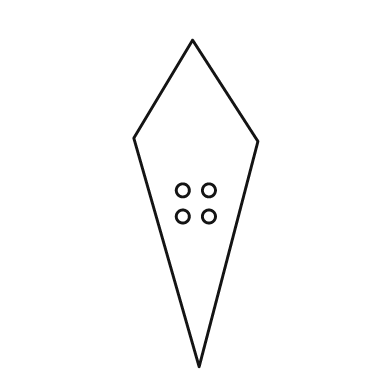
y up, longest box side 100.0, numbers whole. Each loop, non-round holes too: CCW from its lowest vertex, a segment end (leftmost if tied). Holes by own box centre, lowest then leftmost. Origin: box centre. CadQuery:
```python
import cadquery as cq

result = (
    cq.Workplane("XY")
    .moveTo(1.0, -50.0)
    .lineTo(19.0, 19.0)
    .lineTo(-1.0, 50.0)
    .lineTo(-19.0, 20.0)
    .close()
    .moveTo(-4.0, -4.0)
    .circle(2.0)
    .moveTo(4.0, -4.0)
    .circle(2.0)
    .moveTo(-4.0, 4.0)
    .circle(2.0)
    .moveTo(4.0, 4.0)
    .circle(2.0)
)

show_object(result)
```